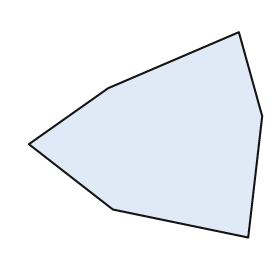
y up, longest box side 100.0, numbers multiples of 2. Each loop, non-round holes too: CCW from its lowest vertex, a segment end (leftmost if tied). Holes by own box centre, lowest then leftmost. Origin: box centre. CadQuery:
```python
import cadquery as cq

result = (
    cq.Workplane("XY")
    .moveTo(44.0, -44.0)
    .lineTo(50.0, 8.0)
    .lineTo(40.0, 44.0)
    .lineTo(-16.0, 20.0)
    .lineTo(-50.0, -4.0)
    .lineTo(-14.0, -32.0)
    .close()
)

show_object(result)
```